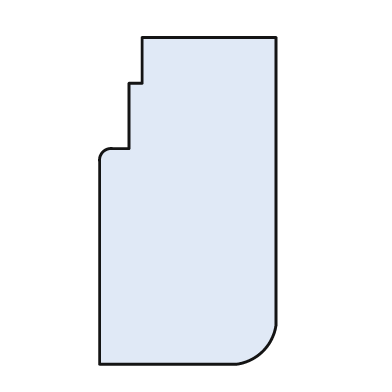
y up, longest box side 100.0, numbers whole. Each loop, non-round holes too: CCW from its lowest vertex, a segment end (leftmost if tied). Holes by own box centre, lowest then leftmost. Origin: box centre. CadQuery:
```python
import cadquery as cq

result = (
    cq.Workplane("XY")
    .moveTo(-27.0, -50.0)
    .lineTo(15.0, -50.0)
    .threePointArc((23.0, -46.0), (27.0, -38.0))
    .lineTo(27.0, 50.0)
    .lineTo(-14.0, 50.0)
    .lineTo(-14.0, 36.0)
    .lineTo(-18.0, 36.0)
    .lineTo(-18.0, 16.0)
    .lineTo(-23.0, 16.0)
    .threePointArc((-26.0, 15.0), (-27.0, 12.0))
    .close()
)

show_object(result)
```